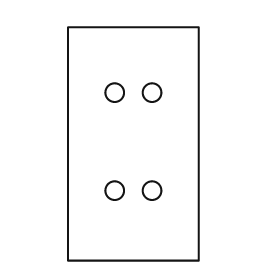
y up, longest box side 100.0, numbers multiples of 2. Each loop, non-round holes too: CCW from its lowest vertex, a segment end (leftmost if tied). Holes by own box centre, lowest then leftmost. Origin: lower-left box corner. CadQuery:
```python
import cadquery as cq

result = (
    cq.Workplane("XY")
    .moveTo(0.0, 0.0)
    .lineTo(56.0, 0.0)
    .lineTo(56.0, 100.0)
    .lineTo(0.0, 100.0)
    .close()
    .moveTo(20.0, 30.0)
    .circle(4.0)
    .moveTo(36.0, 30.0)
    .circle(4.0)
    .moveTo(20.0, 72.0)
    .circle(4.0)
    .moveTo(36.0, 72.0)
    .circle(4.0)
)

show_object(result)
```